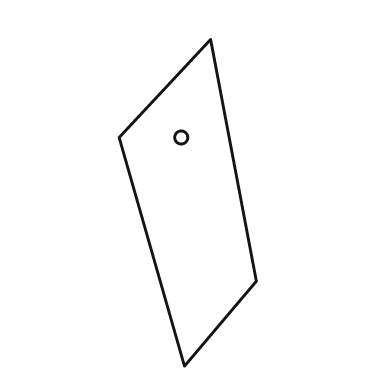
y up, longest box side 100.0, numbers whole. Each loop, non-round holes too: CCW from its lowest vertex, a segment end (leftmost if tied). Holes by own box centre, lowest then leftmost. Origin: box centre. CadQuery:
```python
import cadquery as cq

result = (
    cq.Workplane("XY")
    .moveTo(-1.0, -50.0)
    .lineTo(21.0, -24.0)
    .lineTo(7.0, 50.0)
    .lineTo(-21.0, 20.0)
    .close()
    .moveTo(-2.0, 20.0)
    .circle(2.0)
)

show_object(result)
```